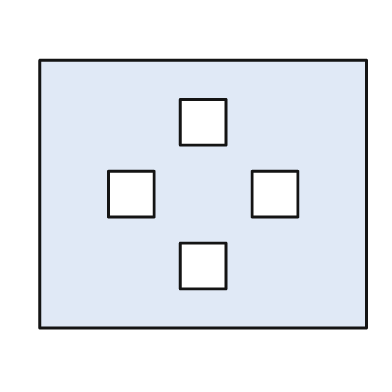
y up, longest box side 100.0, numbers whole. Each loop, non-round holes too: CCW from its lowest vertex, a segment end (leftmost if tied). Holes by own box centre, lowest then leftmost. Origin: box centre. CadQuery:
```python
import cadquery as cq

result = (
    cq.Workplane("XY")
    .moveTo(-50.0, -41.0)
    .lineTo(50.0, -41.0)
    .lineTo(50.0, 41.0)
    .lineTo(-50.0, 41.0)
    .close()
    .moveTo(-7.0, -29.0)
    .lineTo(7.0, -29.0)
    .lineTo(7.0, -15.0)
    .lineTo(-7.0, -15.0)
    .close()
    .moveTo(-29.0, -7.0)
    .lineTo(-15.0, -7.0)
    .lineTo(-15.0, 7.0)
    .lineTo(-29.0, 7.0)
    .close()
    .moveTo(15.0, -7.0)
    .lineTo(29.0, -7.0)
    .lineTo(29.0, 7.0)
    .lineTo(15.0, 7.0)
    .close()
    .moveTo(-7.0, 15.0)
    .lineTo(7.0, 15.0)
    .lineTo(7.0, 29.0)
    .lineTo(-7.0, 29.0)
    .close()
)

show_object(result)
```